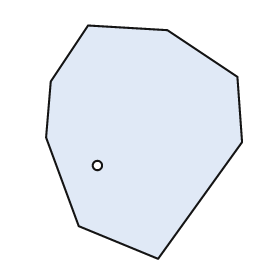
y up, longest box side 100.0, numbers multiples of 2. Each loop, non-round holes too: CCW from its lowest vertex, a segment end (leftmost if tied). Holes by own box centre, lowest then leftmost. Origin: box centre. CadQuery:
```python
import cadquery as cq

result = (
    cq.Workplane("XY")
    .moveTo(6.0, -50.0)
    .lineTo(42.0, 0.0)
    .lineTo(40.0, 28.0)
    .lineTo(10.0, 48.0)
    .lineTo(-24.0, 50.0)
    .lineTo(-40.0, 26.0)
    .lineTo(-42.0, 2.0)
    .lineTo(-28.0, -36.0)
    .close()
    .moveTo(-20.0, -10.0)
    .circle(2.0)
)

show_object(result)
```